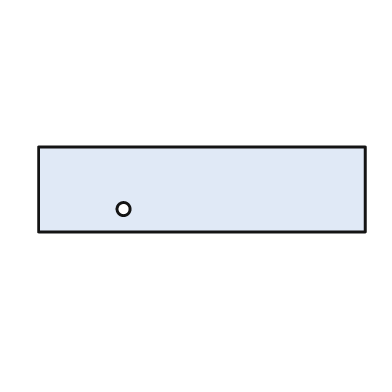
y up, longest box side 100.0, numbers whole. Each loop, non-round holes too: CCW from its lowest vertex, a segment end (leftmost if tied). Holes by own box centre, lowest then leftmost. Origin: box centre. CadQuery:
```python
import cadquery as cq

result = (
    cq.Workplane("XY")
    .moveTo(-50.0, -13.0)
    .lineTo(50.0, -13.0)
    .lineTo(50.0, 13.0)
    .lineTo(-50.0, 13.0)
    .close()
    .moveTo(-24.0, -6.0)
    .circle(2.0)
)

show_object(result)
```